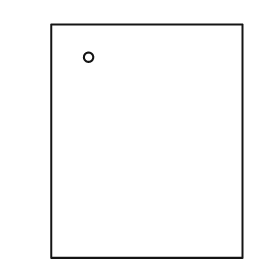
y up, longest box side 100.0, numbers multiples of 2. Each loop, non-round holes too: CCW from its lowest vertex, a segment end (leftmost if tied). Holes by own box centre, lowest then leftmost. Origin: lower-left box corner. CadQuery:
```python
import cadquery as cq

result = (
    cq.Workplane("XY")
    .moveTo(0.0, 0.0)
    .lineTo(82.0, 0.0)
    .lineTo(82.0, 100.0)
    .lineTo(0.0, 100.0)
    .close()
    .moveTo(16.0, 86.0)
    .circle(2.0)
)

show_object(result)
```